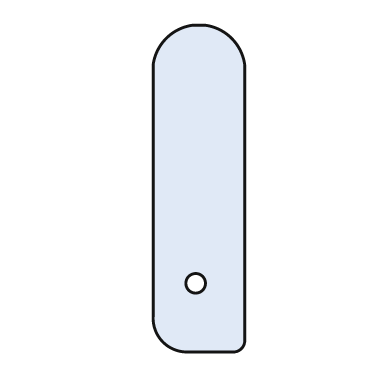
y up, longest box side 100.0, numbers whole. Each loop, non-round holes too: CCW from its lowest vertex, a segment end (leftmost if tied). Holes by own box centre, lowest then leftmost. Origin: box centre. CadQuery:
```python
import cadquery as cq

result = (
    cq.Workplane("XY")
    .moveTo(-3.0, -50.0)
    .lineTo(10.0, -50.0)
    .threePointArc((13.0, -49.0), (14.0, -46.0))
    .lineTo(14.0, 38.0)
    .threePointArc((10.0, 46.0), (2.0, 50.0))
    .lineTo(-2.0, 50.0)
    .threePointArc((-10.0, 46.0), (-14.0, 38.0))
    .lineTo(-14.0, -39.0)
    .threePointArc((-11.0, -47.0), (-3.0, -50.0))
    .close()
    .moveTo(-1.0, -29.0)
    .circle(3.0)
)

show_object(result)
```